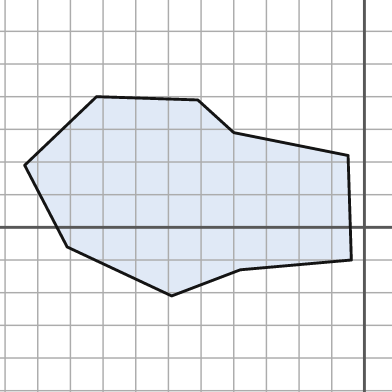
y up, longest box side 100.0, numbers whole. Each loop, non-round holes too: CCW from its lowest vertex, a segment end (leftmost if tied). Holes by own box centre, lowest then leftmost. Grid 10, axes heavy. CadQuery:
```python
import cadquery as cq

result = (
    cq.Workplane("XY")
    .moveTo(-59.0, -21.0)
    .lineTo(-38.0, -13.0)
    .lineTo(-4.0, -10.0)
    .lineTo(-5.0, 22.0)
    .lineTo(-40.0, 29.0)
    .lineTo(-51.0, 39.0)
    .lineTo(-82.0, 40.0)
    .lineTo(-104.0, 19.0)
    .lineTo(-91.0, -6.0)
    .close()
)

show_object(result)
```